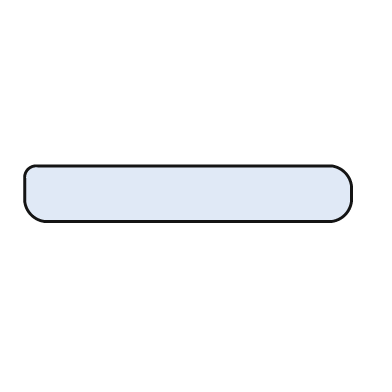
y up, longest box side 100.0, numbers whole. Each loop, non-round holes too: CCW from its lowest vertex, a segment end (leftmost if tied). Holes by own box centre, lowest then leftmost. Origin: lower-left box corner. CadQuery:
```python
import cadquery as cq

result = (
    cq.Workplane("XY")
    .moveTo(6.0, 0.0)
    .lineTo(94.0, 0.0)
    .threePointArc((98.0, 2.0), (100.0, 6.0))
    .lineTo(100.0, 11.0)
    .threePointArc((98.0, 15.0), (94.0, 17.0))
    .lineTo(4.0, 17.0)
    .threePointArc((1.0, 16.0), (0.0, 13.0))
    .lineTo(0.0, 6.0)
    .threePointArc((2.0, 2.0), (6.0, 0.0))
    .close()
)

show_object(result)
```